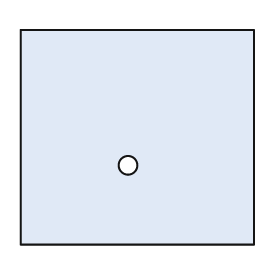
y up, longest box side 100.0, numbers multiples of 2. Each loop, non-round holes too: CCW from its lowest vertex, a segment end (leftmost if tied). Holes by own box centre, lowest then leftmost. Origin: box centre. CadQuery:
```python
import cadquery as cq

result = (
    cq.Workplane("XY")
    .moveTo(-50.0, -46.0)
    .lineTo(50.0, -46.0)
    .lineTo(50.0, 46.0)
    .lineTo(-50.0, 46.0)
    .close()
    .moveTo(-4.0, -12.0)
    .circle(4.0)
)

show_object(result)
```